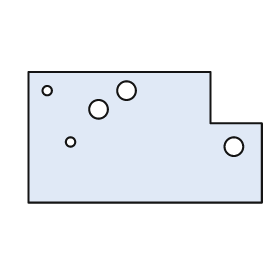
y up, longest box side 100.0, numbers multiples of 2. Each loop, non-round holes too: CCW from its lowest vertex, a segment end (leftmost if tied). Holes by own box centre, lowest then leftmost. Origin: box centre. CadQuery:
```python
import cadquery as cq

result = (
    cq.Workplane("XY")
    .moveTo(-50.0, -28.0)
    .lineTo(50.0, -28.0)
    .lineTo(50.0, 6.0)
    .lineTo(28.0, 6.0)
    .lineTo(28.0, 28.0)
    .lineTo(-50.0, 28.0)
    .close()
    .moveTo(38.0, -4.0)
    .circle(4.0)
    .moveTo(-32.0, -2.0)
    .circle(2.0)
    .moveTo(-20.0, 12.0)
    .circle(4.0)
    .moveTo(-42.0, 20.0)
    .circle(2.0)
    .moveTo(-8.0, 20.0)
    .circle(4.0)
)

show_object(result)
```